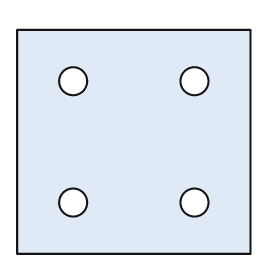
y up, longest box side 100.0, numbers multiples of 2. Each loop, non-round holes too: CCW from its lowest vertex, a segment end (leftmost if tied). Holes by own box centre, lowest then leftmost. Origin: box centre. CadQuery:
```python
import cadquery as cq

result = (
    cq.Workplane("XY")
    .moveTo(-50.0, -48.0)
    .lineTo(50.0, -48.0)
    .lineTo(50.0, 48.0)
    .lineTo(-50.0, 48.0)
    .close()
    .moveTo(-26.0, -26.0)
    .circle(6.0)
    .moveTo(26.0, -26.0)
    .circle(6.0)
    .moveTo(-26.0, 26.0)
    .circle(6.0)
    .moveTo(26.0, 26.0)
    .circle(6.0)
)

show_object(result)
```